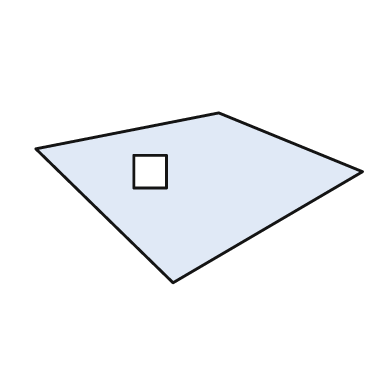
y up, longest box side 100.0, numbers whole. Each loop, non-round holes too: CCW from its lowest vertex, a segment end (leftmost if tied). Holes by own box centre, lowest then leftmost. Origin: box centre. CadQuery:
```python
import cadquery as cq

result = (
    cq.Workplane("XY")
    .moveTo(-8.0, -26.0)
    .lineTo(50.0, 8.0)
    .lineTo(6.0, 26.0)
    .lineTo(-50.0, 15.0)
    .close()
    .moveTo(-20.0, 3.0)
    .lineTo(-10.0, 3.0)
    .lineTo(-10.0, 13.0)
    .lineTo(-20.0, 13.0)
    .close()
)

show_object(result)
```